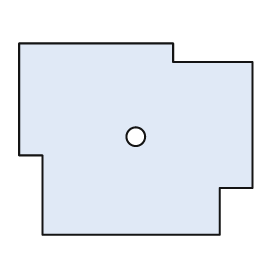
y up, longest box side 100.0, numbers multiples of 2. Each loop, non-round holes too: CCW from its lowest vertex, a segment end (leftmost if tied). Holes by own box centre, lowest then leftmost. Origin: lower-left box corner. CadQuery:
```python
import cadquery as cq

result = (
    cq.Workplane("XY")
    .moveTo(10.0, 0.0)
    .lineTo(86.0, 0.0)
    .lineTo(86.0, 20.0)
    .lineTo(100.0, 20.0)
    .lineTo(100.0, 74.0)
    .lineTo(66.0, 74.0)
    .lineTo(66.0, 82.0)
    .lineTo(0.0, 82.0)
    .lineTo(0.0, 34.0)
    .lineTo(10.0, 34.0)
    .close()
    .moveTo(50.0, 42.0)
    .circle(4.0)
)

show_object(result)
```